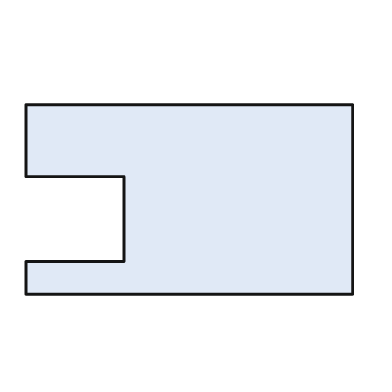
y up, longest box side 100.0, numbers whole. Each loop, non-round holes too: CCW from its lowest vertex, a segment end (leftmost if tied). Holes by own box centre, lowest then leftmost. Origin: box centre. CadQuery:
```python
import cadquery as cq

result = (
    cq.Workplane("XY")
    .moveTo(-50.0, -29.0)
    .lineTo(50.0, -29.0)
    .lineTo(50.0, 29.0)
    .lineTo(-50.0, 29.0)
    .lineTo(-50.0, 7.0)
    .lineTo(-20.0, 7.0)
    .lineTo(-20.0, -19.0)
    .lineTo(-50.0, -19.0)
    .close()
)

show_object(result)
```